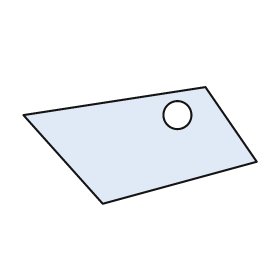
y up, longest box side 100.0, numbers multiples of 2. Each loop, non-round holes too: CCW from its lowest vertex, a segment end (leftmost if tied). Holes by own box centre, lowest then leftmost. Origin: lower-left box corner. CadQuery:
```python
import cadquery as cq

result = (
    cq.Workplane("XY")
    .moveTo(34.0, 0.0)
    .lineTo(100.0, 18.0)
    .lineTo(78.0, 50.0)
    .lineTo(0.0, 38.0)
    .close()
    .moveTo(66.0, 38.0)
    .circle(6.0)
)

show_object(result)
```